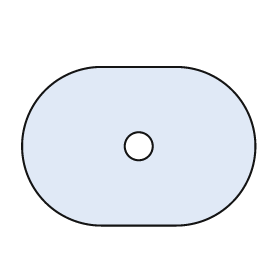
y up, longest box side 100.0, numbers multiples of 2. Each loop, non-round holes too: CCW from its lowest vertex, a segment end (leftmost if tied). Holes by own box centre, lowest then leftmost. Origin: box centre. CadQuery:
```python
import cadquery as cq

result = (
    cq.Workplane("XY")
    .moveTo(-16.0, -34.0)
    .lineTo(16.0, -34.0)
    .threePointArc((50.0, 0.0), (16.0, 34.0))
    .lineTo(-16.0, 34.0)
    .threePointArc((-50.0, 0.0), (-16.0, -34.0))
    .close()
    .moveTo(0.0, 0.0)
    .circle(6.0)
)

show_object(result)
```